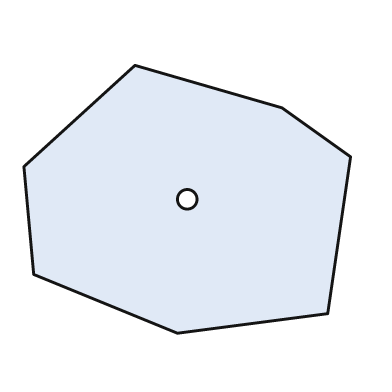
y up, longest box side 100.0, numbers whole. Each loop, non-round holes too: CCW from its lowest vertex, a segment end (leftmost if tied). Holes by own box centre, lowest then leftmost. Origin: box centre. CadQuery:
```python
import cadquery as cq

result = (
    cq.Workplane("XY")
    .moveTo(-3.0, -41.0)
    .lineTo(43.0, -35.0)
    .lineTo(50.0, 13.0)
    .lineTo(29.0, 28.0)
    .lineTo(-16.0, 41.0)
    .lineTo(-50.0, 10.0)
    .lineTo(-47.0, -23.0)
    .close()
    .moveTo(0.0, 0.0)
    .circle(3.0)
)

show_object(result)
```